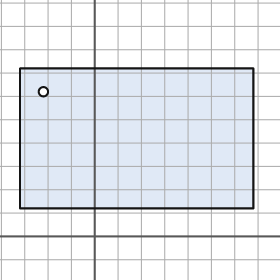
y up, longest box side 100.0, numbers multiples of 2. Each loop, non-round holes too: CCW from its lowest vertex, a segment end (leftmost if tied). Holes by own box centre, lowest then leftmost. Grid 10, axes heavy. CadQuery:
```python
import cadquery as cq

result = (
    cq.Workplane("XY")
    .moveTo(-32.0, 12.0)
    .lineTo(68.0, 12.0)
    .lineTo(68.0, 72.0)
    .lineTo(-32.0, 72.0)
    .close()
    .moveTo(-22.0, 62.0)
    .circle(2.0)
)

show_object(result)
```